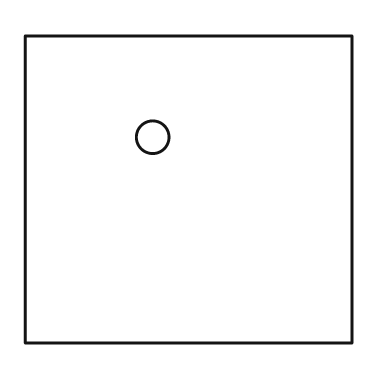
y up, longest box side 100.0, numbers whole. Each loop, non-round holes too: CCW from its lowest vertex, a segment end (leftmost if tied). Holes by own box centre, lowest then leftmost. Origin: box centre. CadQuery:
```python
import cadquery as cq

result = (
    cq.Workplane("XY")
    .moveTo(-50.0, -47.0)
    .lineTo(50.0, -47.0)
    .lineTo(50.0, 47.0)
    .lineTo(-50.0, 47.0)
    .close()
    .moveTo(-11.0, 16.0)
    .circle(5.0)
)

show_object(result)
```